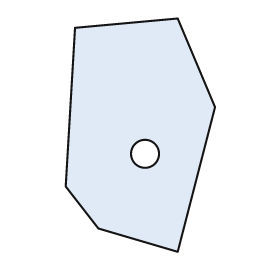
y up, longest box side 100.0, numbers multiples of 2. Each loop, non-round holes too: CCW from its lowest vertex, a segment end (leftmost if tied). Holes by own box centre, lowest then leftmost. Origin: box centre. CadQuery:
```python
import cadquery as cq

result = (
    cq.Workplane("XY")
    .moveTo(16.0, -50.0)
    .lineTo(32.0, 12.0)
    .lineTo(16.0, 50.0)
    .lineTo(-28.0, 46.0)
    .lineTo(-32.0, -22.0)
    .lineTo(-18.0, -40.0)
    .close()
    .moveTo(2.0, -8.0)
    .circle(6.0)
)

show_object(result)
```